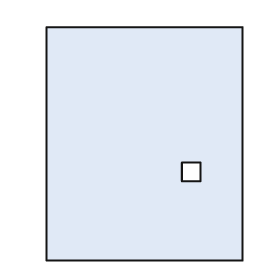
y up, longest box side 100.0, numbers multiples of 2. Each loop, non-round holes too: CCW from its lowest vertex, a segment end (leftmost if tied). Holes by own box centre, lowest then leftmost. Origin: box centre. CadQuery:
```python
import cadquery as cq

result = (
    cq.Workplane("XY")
    .moveTo(-42.0, -50.0)
    .lineTo(42.0, -50.0)
    .lineTo(42.0, 50.0)
    .lineTo(-42.0, 50.0)
    .close()
    .moveTo(16.0, -16.0)
    .lineTo(24.0, -16.0)
    .lineTo(24.0, -8.0)
    .lineTo(16.0, -8.0)
    .close()
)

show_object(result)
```